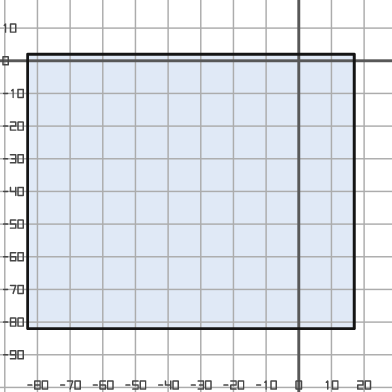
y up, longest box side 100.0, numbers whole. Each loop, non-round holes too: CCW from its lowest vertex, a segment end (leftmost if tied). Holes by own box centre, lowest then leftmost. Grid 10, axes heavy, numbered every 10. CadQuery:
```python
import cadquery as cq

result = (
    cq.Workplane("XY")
    .moveTo(-83.0, -82.0)
    .lineTo(17.0, -82.0)
    .lineTo(17.0, 2.0)
    .lineTo(-83.0, 2.0)
    .close()
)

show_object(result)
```